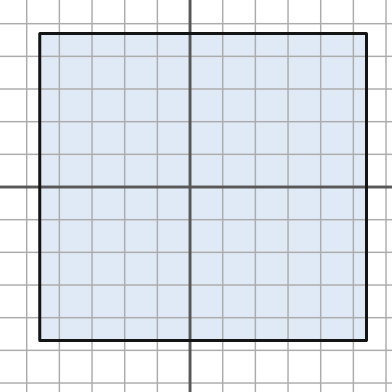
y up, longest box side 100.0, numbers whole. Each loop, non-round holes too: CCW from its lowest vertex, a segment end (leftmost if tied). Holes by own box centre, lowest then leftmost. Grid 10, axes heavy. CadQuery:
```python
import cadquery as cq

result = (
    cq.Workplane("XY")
    .moveTo(-46.0, -47.0)
    .lineTo(54.0, -47.0)
    .lineTo(54.0, 47.0)
    .lineTo(-46.0, 47.0)
    .close()
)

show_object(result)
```